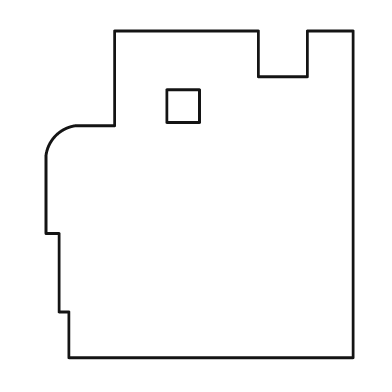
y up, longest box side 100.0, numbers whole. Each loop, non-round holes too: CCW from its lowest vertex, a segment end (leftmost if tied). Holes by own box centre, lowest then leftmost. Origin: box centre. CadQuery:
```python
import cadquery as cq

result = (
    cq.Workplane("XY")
    .moveTo(-40.0, -50.0)
    .lineTo(47.0, -50.0)
    .lineTo(47.0, 50.0)
    .lineTo(33.0, 50.0)
    .lineTo(33.0, 36.0)
    .lineTo(18.0, 36.0)
    .lineTo(18.0, 50.0)
    .lineTo(-26.0, 50.0)
    .lineTo(-26.0, 21.0)
    .lineTo(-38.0, 21.0)
    .threePointArc((-44.0, 18.0), (-47.0, 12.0))
    .lineTo(-47.0, -12.0)
    .lineTo(-43.0, -12.0)
    .lineTo(-43.0, -36.0)
    .lineTo(-40.0, -36.0)
    .close()
    .moveTo(-10.0, 22.0)
    .lineTo(0.0, 22.0)
    .lineTo(0.0, 32.0)
    .lineTo(-10.0, 32.0)
    .close()
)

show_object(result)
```